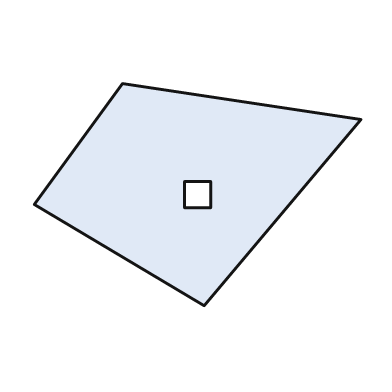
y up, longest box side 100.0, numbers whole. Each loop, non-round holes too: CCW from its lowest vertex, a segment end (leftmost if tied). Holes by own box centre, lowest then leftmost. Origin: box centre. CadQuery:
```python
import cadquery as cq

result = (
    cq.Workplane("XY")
    .moveTo(2.0, -34.0)
    .lineTo(50.0, 23.0)
    .lineTo(-23.0, 34.0)
    .lineTo(-50.0, -3.0)
    .close()
    .moveTo(-4.0, -4.0)
    .lineTo(4.0, -4.0)
    .lineTo(4.0, 4.0)
    .lineTo(-4.0, 4.0)
    .close()
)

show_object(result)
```